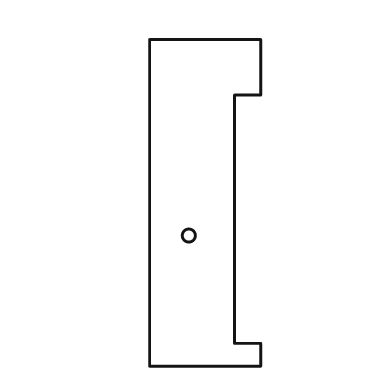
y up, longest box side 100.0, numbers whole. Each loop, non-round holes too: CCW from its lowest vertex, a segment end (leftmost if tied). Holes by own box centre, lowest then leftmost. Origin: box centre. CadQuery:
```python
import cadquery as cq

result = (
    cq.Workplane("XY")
    .moveTo(-17.0, -50.0)
    .lineTo(17.0, -50.0)
    .lineTo(17.0, -43.0)
    .lineTo(9.0, -43.0)
    .lineTo(9.0, 33.0)
    .lineTo(17.0, 33.0)
    .lineTo(17.0, 50.0)
    .lineTo(-17.0, 50.0)
    .close()
    .moveTo(-5.0, -10.0)
    .circle(2.0)
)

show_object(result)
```